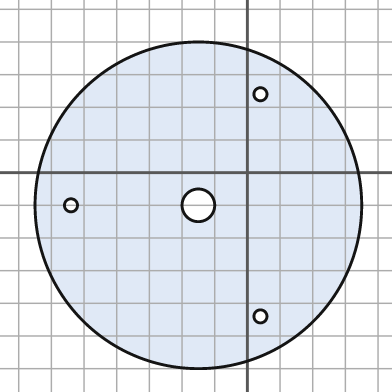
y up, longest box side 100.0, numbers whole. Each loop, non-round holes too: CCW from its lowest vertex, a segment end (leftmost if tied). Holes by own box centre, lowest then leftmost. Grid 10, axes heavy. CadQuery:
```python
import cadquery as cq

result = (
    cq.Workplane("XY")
    .moveTo(-15.0, -10.0)
    .circle(50.0)
    .moveTo(4.0, -44.0)
    .circle(2.0)
    .moveTo(-54.0, -10.0)
    .circle(2.0)
    .moveTo(-15.0, -10.0)
    .circle(5.0)
    .moveTo(4.0, 24.0)
    .circle(2.0)
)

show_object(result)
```